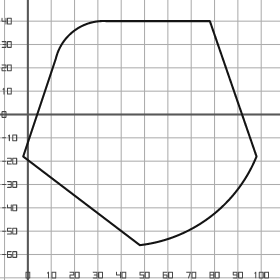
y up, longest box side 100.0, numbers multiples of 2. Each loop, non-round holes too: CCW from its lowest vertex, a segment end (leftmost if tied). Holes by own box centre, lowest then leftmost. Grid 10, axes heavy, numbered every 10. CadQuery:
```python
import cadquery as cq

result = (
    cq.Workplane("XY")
    .moveTo(48.0, -56.0)
    .threePointArc((78.0, -44.0), (98.0, -18.0))
    .lineTo(78.0, 40.0)
    .lineTo(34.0, 40.0)
    .threePointArc((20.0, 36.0), (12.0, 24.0))
    .lineTo(-2.0, -18.0)
    .close()
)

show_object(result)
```